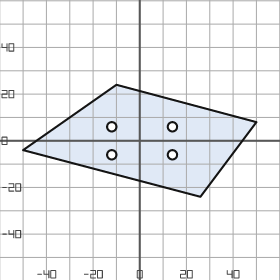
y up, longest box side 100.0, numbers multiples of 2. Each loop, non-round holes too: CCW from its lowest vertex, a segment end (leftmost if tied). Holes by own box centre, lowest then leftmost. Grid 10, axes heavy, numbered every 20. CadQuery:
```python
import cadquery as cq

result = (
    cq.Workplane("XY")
    .moveTo(26.0, -24.0)
    .lineTo(50.0, 8.0)
    .lineTo(-10.0, 24.0)
    .lineTo(-50.0, -4.0)
    .close()
    .moveTo(-12.0, -6.0)
    .circle(2.0)
    .moveTo(14.0, -6.0)
    .circle(2.0)
    .moveTo(-12.0, 6.0)
    .circle(2.0)
    .moveTo(14.0, 6.0)
    .circle(2.0)
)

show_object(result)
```